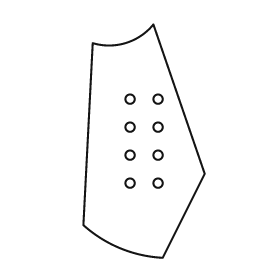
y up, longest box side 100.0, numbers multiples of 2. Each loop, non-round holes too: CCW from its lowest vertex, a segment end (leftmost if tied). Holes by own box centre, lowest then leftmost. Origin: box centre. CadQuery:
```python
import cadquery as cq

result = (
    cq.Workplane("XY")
    .moveTo(8.0, -50.0)
    .lineTo(26.0, -14.0)
    .lineTo(4.0, 50.0)
    .threePointArc((-8.0, 42.0), (-22.0, 42.0))
    .lineTo(-26.0, -36.0)
    .threePointArc((-10.0, -46.0), (8.0, -50.0))
    .close()
    .moveTo(-6.0, -18.0)
    .circle(2.0)
    .moveTo(6.0, -18.0)
    .circle(2.0)
    .moveTo(-6.0, -6.0)
    .circle(2.0)
    .moveTo(6.0, -6.0)
    .circle(2.0)
    .moveTo(-6.0, 6.0)
    .circle(2.0)
    .moveTo(6.0, 6.0)
    .circle(2.0)
    .moveTo(-6.0, 18.0)
    .circle(2.0)
    .moveTo(6.0, 18.0)
    .circle(2.0)
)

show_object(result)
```